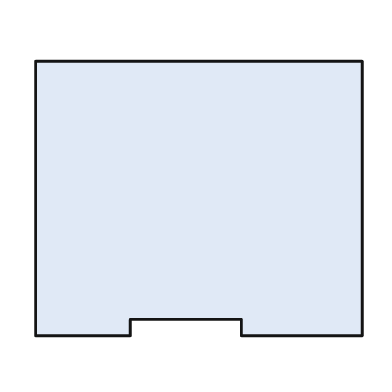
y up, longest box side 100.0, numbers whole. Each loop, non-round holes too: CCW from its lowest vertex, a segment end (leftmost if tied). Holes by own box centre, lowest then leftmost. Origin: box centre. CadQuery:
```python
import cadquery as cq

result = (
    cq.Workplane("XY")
    .moveTo(-50.0, -42.0)
    .lineTo(-21.0, -42.0)
    .lineTo(-21.0, -37.0)
    .lineTo(13.0, -37.0)
    .lineTo(13.0, -42.0)
    .lineTo(50.0, -42.0)
    .lineTo(50.0, 42.0)
    .lineTo(-50.0, 42.0)
    .close()
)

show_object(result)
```